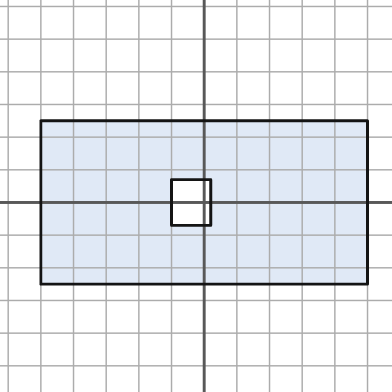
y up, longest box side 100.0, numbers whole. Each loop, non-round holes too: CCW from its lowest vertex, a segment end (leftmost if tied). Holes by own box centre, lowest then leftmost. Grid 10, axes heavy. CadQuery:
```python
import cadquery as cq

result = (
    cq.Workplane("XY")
    .moveTo(-50.0, -25.0)
    .lineTo(50.0, -25.0)
    .lineTo(50.0, 25.0)
    .lineTo(-50.0, 25.0)
    .close()
    .moveTo(-10.0, -7.0)
    .lineTo(2.0, -7.0)
    .lineTo(2.0, 7.0)
    .lineTo(-10.0, 7.0)
    .close()
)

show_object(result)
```